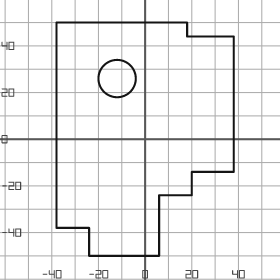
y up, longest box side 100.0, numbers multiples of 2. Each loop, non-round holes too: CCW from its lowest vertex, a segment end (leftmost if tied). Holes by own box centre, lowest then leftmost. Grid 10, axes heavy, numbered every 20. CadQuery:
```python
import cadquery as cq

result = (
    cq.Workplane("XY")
    .moveTo(-24.0, -50.0)
    .lineTo(6.0, -50.0)
    .lineTo(6.0, -24.0)
    .lineTo(20.0, -24.0)
    .lineTo(20.0, -14.0)
    .lineTo(38.0, -14.0)
    .lineTo(38.0, 44.0)
    .lineTo(18.0, 44.0)
    .lineTo(18.0, 50.0)
    .lineTo(-38.0, 50.0)
    .lineTo(-38.0, -38.0)
    .lineTo(-24.0, -38.0)
    .close()
    .moveTo(-12.0, 26.0)
    .circle(8.0)
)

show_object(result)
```